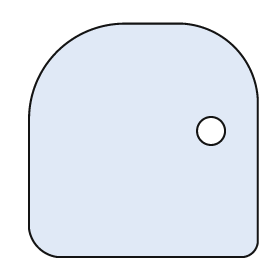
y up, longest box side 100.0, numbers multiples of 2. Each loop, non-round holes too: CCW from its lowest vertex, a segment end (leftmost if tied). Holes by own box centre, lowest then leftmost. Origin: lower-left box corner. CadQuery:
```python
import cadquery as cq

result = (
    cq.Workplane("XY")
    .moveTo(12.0, 0.0)
    .lineTo(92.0, 0.0)
    .threePointArc((96.0, 2.0), (98.0, 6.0))
    .lineTo(98.0, 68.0)
    .threePointArc((88.0, 90.0), (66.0, 100.0))
    .lineTo(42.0, 100.0)
    .threePointArc((12.0, 88.0), (0.0, 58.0))
    .lineTo(0.0, 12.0)
    .threePointArc((4.0, 4.0), (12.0, 0.0))
    .close()
    .moveTo(78.0, 54.0)
    .circle(6.0)
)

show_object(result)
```